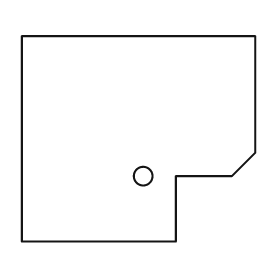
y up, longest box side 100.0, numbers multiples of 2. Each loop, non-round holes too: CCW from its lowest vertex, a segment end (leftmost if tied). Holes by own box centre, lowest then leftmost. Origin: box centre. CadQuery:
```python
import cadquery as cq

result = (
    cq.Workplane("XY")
    .moveTo(-50.0, -44.0)
    .lineTo(16.0, -44.0)
    .lineTo(16.0, -16.0)
    .lineTo(40.0, -16.0)
    .lineTo(50.0, -6.0)
    .lineTo(50.0, 44.0)
    .lineTo(-50.0, 44.0)
    .close()
    .moveTo(2.0, -16.0)
    .circle(4.0)
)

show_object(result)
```